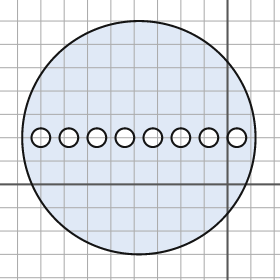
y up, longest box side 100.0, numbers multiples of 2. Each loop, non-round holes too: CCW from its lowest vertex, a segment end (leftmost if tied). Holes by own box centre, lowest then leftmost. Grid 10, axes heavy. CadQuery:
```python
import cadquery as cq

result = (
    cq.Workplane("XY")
    .moveTo(-38.0, 20.0)
    .circle(50.0)
    .moveTo(-80.0, 20.0)
    .circle(4.0)
    .moveTo(-68.0, 20.0)
    .circle(4.0)
    .moveTo(-56.0, 20.0)
    .circle(4.0)
    .moveTo(-44.0, 20.0)
    .circle(4.0)
    .moveTo(-32.0, 20.0)
    .circle(4.0)
    .moveTo(-20.0, 20.0)
    .circle(4.0)
    .moveTo(-8.0, 20.0)
    .circle(4.0)
    .moveTo(4.0, 20.0)
    .circle(4.0)
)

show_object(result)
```